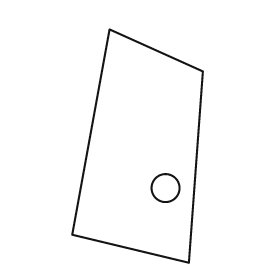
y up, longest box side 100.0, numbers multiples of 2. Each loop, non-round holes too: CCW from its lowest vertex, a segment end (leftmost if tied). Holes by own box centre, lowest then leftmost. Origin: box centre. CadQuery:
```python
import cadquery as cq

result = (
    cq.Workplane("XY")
    .moveTo(22.0, -50.0)
    .lineTo(28.0, 32.0)
    .lineTo(-12.0, 50.0)
    .lineTo(-28.0, -38.0)
    .close()
    .moveTo(12.0, -18.0)
    .circle(6.0)
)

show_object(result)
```